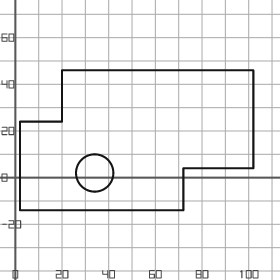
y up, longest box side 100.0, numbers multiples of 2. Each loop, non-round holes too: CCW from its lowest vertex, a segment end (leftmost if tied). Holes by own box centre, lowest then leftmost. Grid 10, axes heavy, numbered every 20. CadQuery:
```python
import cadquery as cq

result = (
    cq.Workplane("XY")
    .moveTo(2.0, -14.0)
    .lineTo(72.0, -14.0)
    .lineTo(72.0, 4.0)
    .lineTo(102.0, 4.0)
    .lineTo(102.0, 46.0)
    .lineTo(20.0, 46.0)
    .lineTo(20.0, 24.0)
    .lineTo(2.0, 24.0)
    .close()
    .moveTo(34.0, 2.0)
    .circle(8.0)
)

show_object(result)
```